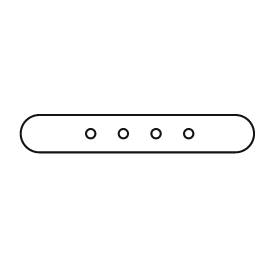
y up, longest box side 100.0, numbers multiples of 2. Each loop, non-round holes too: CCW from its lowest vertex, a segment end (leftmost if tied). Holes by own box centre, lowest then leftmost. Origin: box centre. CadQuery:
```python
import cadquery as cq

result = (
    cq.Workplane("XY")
    .moveTo(-42.0, -8.0)
    .lineTo(42.0, -8.0)
    .threePointArc((50.0, 0.0), (42.0, 8.0))
    .lineTo(-42.0, 8.0)
    .threePointArc((-50.0, 0.0), (-42.0, -8.0))
    .close()
    .moveTo(-20.0, 0.0)
    .circle(2.0)
    .moveTo(-6.0, 0.0)
    .circle(2.0)
    .moveTo(8.0, 0.0)
    .circle(2.0)
    .moveTo(22.0, 0.0)
    .circle(2.0)
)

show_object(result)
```